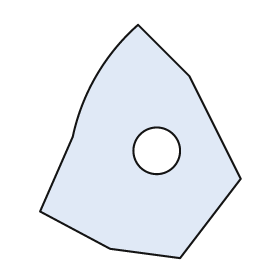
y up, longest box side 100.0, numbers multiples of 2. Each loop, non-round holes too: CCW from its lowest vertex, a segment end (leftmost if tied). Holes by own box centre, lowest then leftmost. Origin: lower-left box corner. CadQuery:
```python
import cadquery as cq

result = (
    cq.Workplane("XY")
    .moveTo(60.0, 0.0)
    .lineTo(86.0, 34.0)
    .lineTo(64.0, 78.0)
    .lineTo(42.0, 100.0)
    .threePointArc((24.0, 78.0), (14.0, 52.0))
    .lineTo(0.0, 20.0)
    .lineTo(30.0, 4.0)
    .close()
    .moveTo(50.0, 46.0)
    .circle(10.0)
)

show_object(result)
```